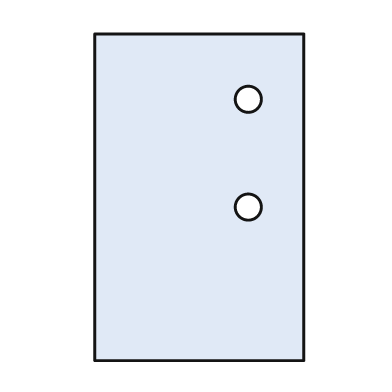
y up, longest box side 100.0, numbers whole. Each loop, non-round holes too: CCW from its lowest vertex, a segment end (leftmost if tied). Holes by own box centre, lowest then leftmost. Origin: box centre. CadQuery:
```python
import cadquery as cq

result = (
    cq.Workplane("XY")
    .moveTo(-32.0, -50.0)
    .lineTo(32.0, -50.0)
    .lineTo(32.0, 50.0)
    .lineTo(-32.0, 50.0)
    .close()
    .moveTo(15.0, -3.0)
    .circle(4.0)
    .moveTo(15.0, 30.0)
    .circle(4.0)
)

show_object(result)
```